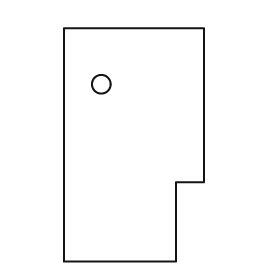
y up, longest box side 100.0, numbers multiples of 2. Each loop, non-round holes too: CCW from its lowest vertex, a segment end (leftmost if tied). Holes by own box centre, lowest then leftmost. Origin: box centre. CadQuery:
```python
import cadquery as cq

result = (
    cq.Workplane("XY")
    .moveTo(-30.0, -50.0)
    .lineTo(18.0, -50.0)
    .lineTo(18.0, -16.0)
    .lineTo(30.0, -16.0)
    .lineTo(30.0, 50.0)
    .lineTo(-30.0, 50.0)
    .close()
    .moveTo(-14.0, 26.0)
    .circle(4.0)
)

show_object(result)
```